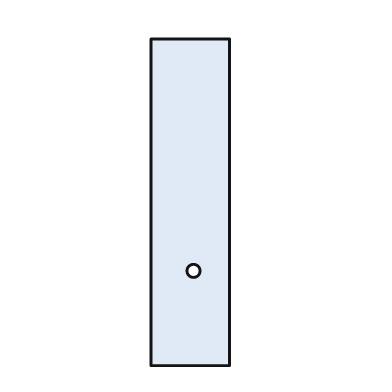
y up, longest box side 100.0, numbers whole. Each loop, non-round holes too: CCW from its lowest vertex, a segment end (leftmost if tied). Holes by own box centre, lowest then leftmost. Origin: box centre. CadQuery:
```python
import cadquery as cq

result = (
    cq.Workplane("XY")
    .moveTo(-12.0, -50.0)
    .lineTo(12.0, -50.0)
    .lineTo(12.0, 50.0)
    .lineTo(-12.0, 50.0)
    .close()
    .moveTo(1.0, -21.0)
    .circle(2.0)
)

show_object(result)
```